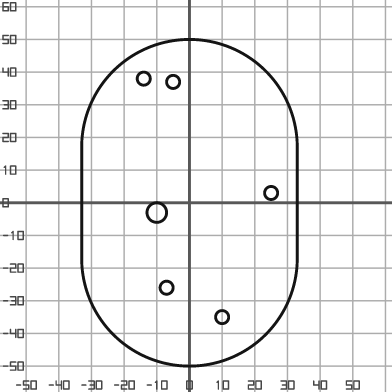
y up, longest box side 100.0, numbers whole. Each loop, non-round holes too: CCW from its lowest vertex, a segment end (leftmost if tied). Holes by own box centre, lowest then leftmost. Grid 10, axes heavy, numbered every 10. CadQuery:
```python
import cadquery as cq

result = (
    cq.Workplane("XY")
    .moveTo(-33.0, -17.0)
    .threePointArc((0.0, -50.0), (33.0, -17.0))
    .lineTo(33.0, 17.0)
    .threePointArc((0.0, 50.0), (-33.0, 17.0))
    .close()
    .moveTo(10.0, -35.0)
    .circle(2.0)
    .moveTo(-7.0, -26.0)
    .circle(2.0)
    .moveTo(-10.0, -3.0)
    .circle(3.0)
    .moveTo(25.0, 3.0)
    .circle(2.0)
    .moveTo(-5.0, 37.0)
    .circle(2.0)
    .moveTo(-14.0, 38.0)
    .circle(2.0)
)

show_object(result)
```